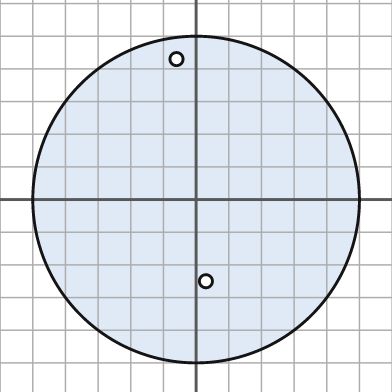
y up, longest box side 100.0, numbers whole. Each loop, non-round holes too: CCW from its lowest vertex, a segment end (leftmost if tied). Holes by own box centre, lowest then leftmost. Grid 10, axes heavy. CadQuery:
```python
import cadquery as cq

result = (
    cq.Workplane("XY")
    .moveTo(0.0, 0.0)
    .circle(50.0)
    .moveTo(3.0, -25.0)
    .circle(2.0)
    .moveTo(-6.0, 43.0)
    .circle(2.0)
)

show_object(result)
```